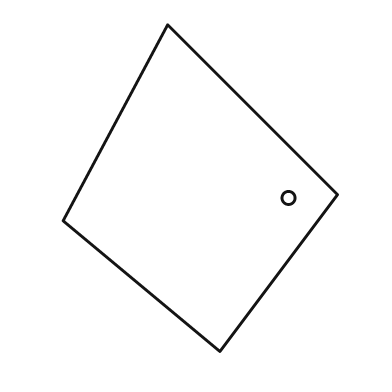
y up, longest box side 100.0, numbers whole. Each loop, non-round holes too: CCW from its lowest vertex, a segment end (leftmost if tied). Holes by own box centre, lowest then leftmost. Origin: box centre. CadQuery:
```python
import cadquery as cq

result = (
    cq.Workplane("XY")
    .moveTo(6.0, -50.0)
    .lineTo(42.0, -2.0)
    .lineTo(-10.0, 50.0)
    .lineTo(-42.0, -10.0)
    .close()
    .moveTo(27.0, -3.0)
    .circle(2.0)
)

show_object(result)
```